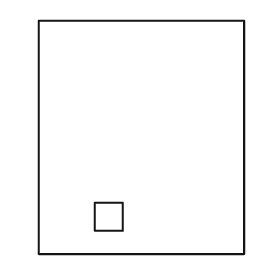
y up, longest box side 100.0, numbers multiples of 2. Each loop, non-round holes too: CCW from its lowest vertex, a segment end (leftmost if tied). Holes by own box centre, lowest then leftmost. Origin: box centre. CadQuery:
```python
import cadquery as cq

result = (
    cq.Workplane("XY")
    .moveTo(-44.0, -50.0)
    .lineTo(44.0, -50.0)
    .lineTo(44.0, 50.0)
    .lineTo(-44.0, 50.0)
    .close()
    .moveTo(-20.0, -40.0)
    .lineTo(-8.0, -40.0)
    .lineTo(-8.0, -28.0)
    .lineTo(-20.0, -28.0)
    .close()
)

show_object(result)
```